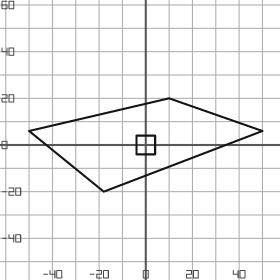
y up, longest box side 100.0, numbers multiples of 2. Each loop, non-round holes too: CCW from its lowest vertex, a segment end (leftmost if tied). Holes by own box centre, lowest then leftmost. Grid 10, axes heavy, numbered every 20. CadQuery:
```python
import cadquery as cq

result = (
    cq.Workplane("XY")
    .moveTo(-18.0, -20.0)
    .lineTo(50.0, 6.0)
    .lineTo(10.0, 20.0)
    .lineTo(-50.0, 6.0)
    .close()
    .moveTo(-4.0, -4.0)
    .lineTo(4.0, -4.0)
    .lineTo(4.0, 4.0)
    .lineTo(-4.0, 4.0)
    .close()
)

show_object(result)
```